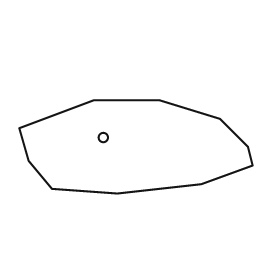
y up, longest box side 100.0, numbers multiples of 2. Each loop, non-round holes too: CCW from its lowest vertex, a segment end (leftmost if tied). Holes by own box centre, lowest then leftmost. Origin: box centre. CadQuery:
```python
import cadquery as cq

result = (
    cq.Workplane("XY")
    .moveTo(-8.0, -20.0)
    .lineTo(28.0, -16.0)
    .lineTo(50.0, -8.0)
    .lineTo(48.0, 0.0)
    .lineTo(36.0, 12.0)
    .lineTo(10.0, 20.0)
    .lineTo(-18.0, 20.0)
    .lineTo(-50.0, 8.0)
    .lineTo(-46.0, -6.0)
    .lineTo(-36.0, -18.0)
    .close()
    .moveTo(-14.0, 4.0)
    .circle(2.0)
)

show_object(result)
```